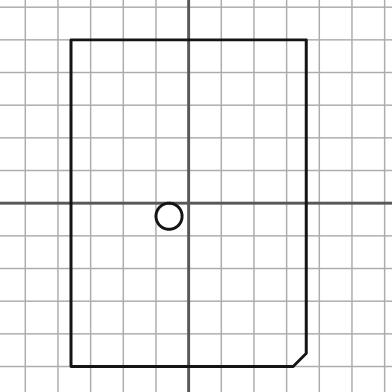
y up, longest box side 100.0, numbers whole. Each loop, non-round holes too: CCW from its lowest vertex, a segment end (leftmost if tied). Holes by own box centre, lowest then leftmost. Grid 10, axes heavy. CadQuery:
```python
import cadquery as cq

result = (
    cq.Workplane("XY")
    .moveTo(-36.0, -50.0)
    .lineTo(32.0, -50.0)
    .lineTo(36.0, -46.0)
    .lineTo(36.0, 50.0)
    .lineTo(-36.0, 50.0)
    .close()
    .moveTo(-6.0, -4.0)
    .circle(4.0)
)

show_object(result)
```